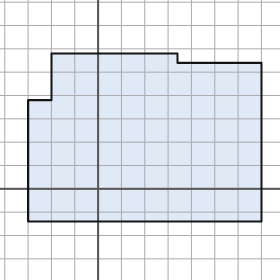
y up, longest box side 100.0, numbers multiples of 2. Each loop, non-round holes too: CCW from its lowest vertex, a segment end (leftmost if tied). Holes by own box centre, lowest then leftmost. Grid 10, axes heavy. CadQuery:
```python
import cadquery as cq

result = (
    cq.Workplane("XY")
    .moveTo(-30.0, -14.0)
    .lineTo(70.0, -14.0)
    .lineTo(70.0, 54.0)
    .lineTo(34.0, 54.0)
    .lineTo(34.0, 58.0)
    .lineTo(-20.0, 58.0)
    .lineTo(-20.0, 38.0)
    .lineTo(-30.0, 38.0)
    .close()
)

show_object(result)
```